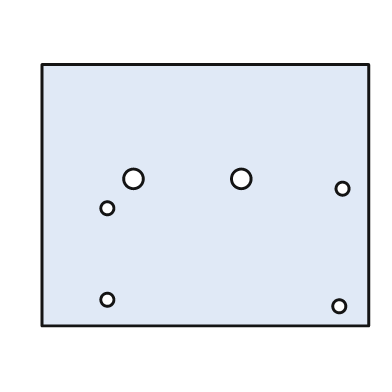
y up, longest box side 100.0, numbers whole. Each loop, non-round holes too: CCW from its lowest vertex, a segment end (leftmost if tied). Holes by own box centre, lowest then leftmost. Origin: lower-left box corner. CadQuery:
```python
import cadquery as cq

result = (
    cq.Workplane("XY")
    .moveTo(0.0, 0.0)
    .lineTo(100.0, 0.0)
    .lineTo(100.0, 80.0)
    .lineTo(0.0, 80.0)
    .close()
    .moveTo(91.0, 6.0)
    .circle(2.0)
    .moveTo(20.0, 8.0)
    .circle(2.0)
    .moveTo(20.0, 36.0)
    .circle(2.0)
    .moveTo(92.0, 42.0)
    .circle(2.0)
    .moveTo(28.0, 45.0)
    .circle(3.0)
    .moveTo(61.0, 45.0)
    .circle(3.0)
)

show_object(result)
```